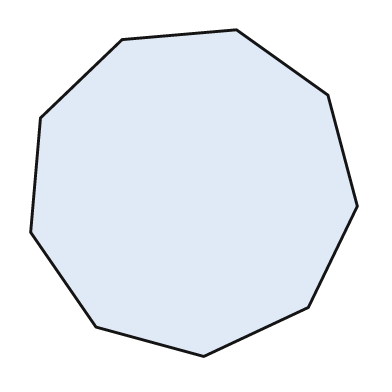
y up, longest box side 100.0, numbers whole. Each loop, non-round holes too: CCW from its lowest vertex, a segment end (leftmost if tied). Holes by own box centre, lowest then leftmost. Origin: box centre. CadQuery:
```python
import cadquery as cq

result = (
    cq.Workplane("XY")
    .moveTo(3.0, -50.0)
    .lineTo(35.0, -35.0)
    .lineTo(50.0, -4.0)
    .lineTo(41.0, 30.0)
    .lineTo(13.0, 50.0)
    .lineTo(-22.0, 47.0)
    .lineTo(-47.0, 23.0)
    .lineTo(-50.0, -12.0)
    .lineTo(-30.0, -41.0)
    .close()
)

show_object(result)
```